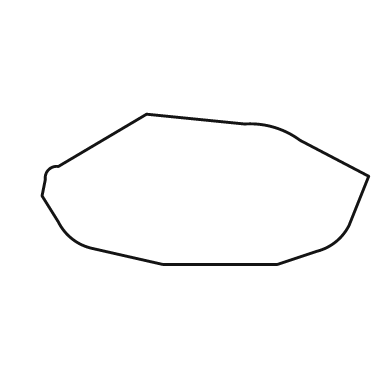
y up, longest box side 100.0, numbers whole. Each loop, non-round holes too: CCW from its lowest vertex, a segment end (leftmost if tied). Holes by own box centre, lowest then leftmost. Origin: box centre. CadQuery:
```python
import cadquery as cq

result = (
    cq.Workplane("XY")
    .moveTo(-13.0, -23.0)
    .lineTo(22.0, -23.0)
    .lineTo(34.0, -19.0)
    .threePointArc((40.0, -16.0), (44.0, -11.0))
    .lineTo(50.0, 4.0)
    .lineTo(29.0, 15.0)
    .threePointArc((21.0, 19.0), (12.0, 20.0))
    .lineTo(-18.0, 23.0)
    .lineTo(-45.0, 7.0)
    .threePointArc((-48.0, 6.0), (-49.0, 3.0))
    .lineTo(-50.0, -2.0)
    .lineTo(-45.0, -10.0)
    .threePointArc((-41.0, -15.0), (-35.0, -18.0))
    .close()
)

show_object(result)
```